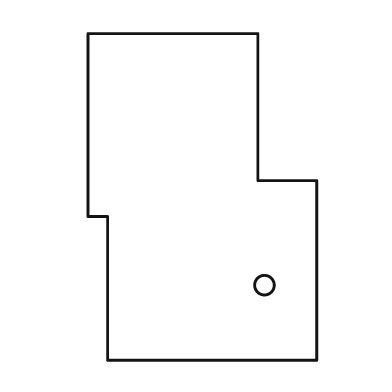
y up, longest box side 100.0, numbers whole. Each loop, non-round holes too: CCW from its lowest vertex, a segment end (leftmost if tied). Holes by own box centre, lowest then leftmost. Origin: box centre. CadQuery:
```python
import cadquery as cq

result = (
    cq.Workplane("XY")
    .moveTo(-29.0, -50.0)
    .lineTo(35.0, -50.0)
    .lineTo(35.0, 5.0)
    .lineTo(17.0, 5.0)
    .lineTo(17.0, 50.0)
    .lineTo(-35.0, 50.0)
    .lineTo(-35.0, -6.0)
    .lineTo(-29.0, -6.0)
    .close()
    .moveTo(19.0, -27.0)
    .circle(3.0)
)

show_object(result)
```